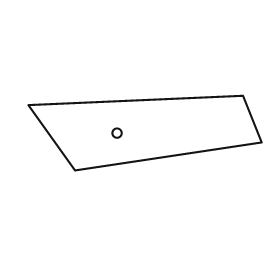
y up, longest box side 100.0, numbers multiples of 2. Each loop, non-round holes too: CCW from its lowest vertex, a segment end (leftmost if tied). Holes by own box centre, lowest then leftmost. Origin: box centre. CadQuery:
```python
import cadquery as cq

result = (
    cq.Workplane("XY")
    .moveTo(-30.0, -16.0)
    .lineTo(50.0, -4.0)
    .lineTo(42.0, 16.0)
    .lineTo(-50.0, 12.0)
    .close()
    .moveTo(-12.0, 0.0)
    .circle(2.0)
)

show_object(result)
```